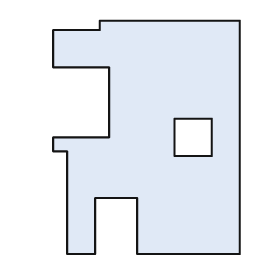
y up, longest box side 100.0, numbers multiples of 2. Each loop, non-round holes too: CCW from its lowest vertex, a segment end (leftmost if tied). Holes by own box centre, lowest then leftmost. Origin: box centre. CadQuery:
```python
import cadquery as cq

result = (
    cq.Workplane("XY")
    .moveTo(-34.0, -50.0)
    .lineTo(-22.0, -50.0)
    .lineTo(-22.0, -26.0)
    .lineTo(-4.0, -26.0)
    .lineTo(-4.0, -50.0)
    .lineTo(40.0, -50.0)
    .lineTo(40.0, 50.0)
    .lineTo(-20.0, 50.0)
    .lineTo(-20.0, 46.0)
    .lineTo(-40.0, 46.0)
    .lineTo(-40.0, 30.0)
    .lineTo(-16.0, 30.0)
    .lineTo(-16.0, 0.0)
    .lineTo(-40.0, 0.0)
    .lineTo(-40.0, -6.0)
    .lineTo(-34.0, -6.0)
    .close()
    .moveTo(12.0, -8.0)
    .lineTo(28.0, -8.0)
    .lineTo(28.0, 8.0)
    .lineTo(12.0, 8.0)
    .close()
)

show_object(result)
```